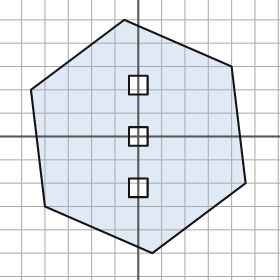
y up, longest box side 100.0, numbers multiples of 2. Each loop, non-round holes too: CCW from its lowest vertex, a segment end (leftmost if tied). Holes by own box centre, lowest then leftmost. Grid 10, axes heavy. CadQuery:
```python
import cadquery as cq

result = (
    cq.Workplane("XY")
    .moveTo(6.0, -50.0)
    .lineTo(46.0, -20.0)
    .lineTo(40.0, 30.0)
    .lineTo(-6.0, 50.0)
    .lineTo(-46.0, 20.0)
    .lineTo(-40.0, -30.0)
    .close()
    .moveTo(-4.0, -26.0)
    .lineTo(4.0, -26.0)
    .lineTo(4.0, -18.0)
    .lineTo(-4.0, -18.0)
    .close()
    .moveTo(-4.0, -4.0)
    .lineTo(4.0, -4.0)
    .lineTo(4.0, 4.0)
    .lineTo(-4.0, 4.0)
    .close()
    .moveTo(-4.0, 18.0)
    .lineTo(4.0, 18.0)
    .lineTo(4.0, 26.0)
    .lineTo(-4.0, 26.0)
    .close()
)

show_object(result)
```